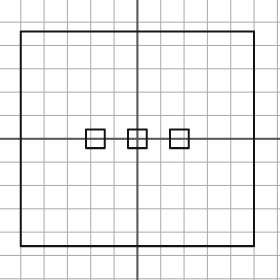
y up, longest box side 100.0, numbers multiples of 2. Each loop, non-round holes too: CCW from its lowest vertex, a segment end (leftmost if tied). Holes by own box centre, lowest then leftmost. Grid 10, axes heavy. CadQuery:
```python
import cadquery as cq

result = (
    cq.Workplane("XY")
    .moveTo(-50.0, -46.0)
    .lineTo(50.0, -46.0)
    .lineTo(50.0, 46.0)
    .lineTo(-50.0, 46.0)
    .close()
    .moveTo(-22.0, -4.0)
    .lineTo(-14.0, -4.0)
    .lineTo(-14.0, 4.0)
    .lineTo(-22.0, 4.0)
    .close()
    .moveTo(-4.0, -4.0)
    .lineTo(4.0, -4.0)
    .lineTo(4.0, 4.0)
    .lineTo(-4.0, 4.0)
    .close()
    .moveTo(14.0, -4.0)
    .lineTo(22.0, -4.0)
    .lineTo(22.0, 4.0)
    .lineTo(14.0, 4.0)
    .close()
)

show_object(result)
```